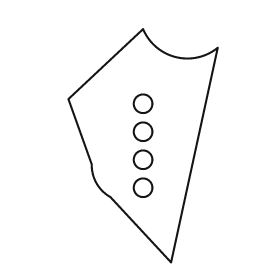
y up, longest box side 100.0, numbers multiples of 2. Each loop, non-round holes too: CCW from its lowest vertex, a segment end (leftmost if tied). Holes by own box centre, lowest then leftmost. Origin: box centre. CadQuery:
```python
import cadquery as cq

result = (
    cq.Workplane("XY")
    .moveTo(12.0, -50.0)
    .lineTo(32.0, 42.0)
    .threePointArc((14.0, 38.0), (0.0, 50.0))
    .lineTo(-32.0, 20.0)
    .lineTo(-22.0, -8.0)
    .threePointArc((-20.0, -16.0), (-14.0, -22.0))
    .close()
    .moveTo(0.0, -18.0)
    .circle(4.0)
    .moveTo(0.0, -6.0)
    .circle(4.0)
    .moveTo(0.0, 6.0)
    .circle(4.0)
    .moveTo(0.0, 18.0)
    .circle(4.0)
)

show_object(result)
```